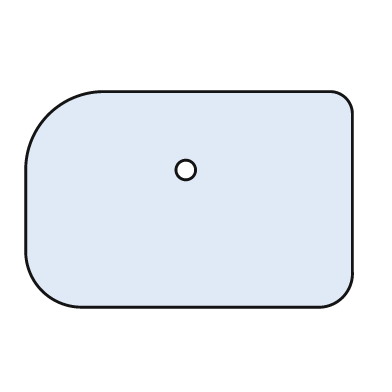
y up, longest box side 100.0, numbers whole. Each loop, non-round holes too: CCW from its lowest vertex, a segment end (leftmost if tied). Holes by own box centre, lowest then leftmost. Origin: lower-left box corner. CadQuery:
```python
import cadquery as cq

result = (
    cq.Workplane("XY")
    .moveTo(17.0, 0.0)
    .lineTo(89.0, 0.0)
    .threePointArc((97.0, 3.0), (100.0, 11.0))
    .lineTo(100.0, 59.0)
    .threePointArc((98.0, 64.0), (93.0, 66.0))
    .lineTo(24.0, 66.0)
    .threePointArc((7.0, 59.0), (0.0, 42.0))
    .lineTo(0.0, 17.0)
    .threePointArc((5.0, 5.0), (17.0, 0.0))
    .close()
    .moveTo(49.0, 42.0)
    .circle(3.0)
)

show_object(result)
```